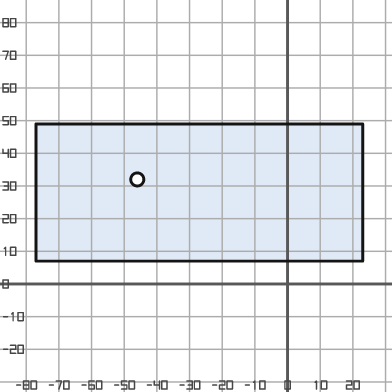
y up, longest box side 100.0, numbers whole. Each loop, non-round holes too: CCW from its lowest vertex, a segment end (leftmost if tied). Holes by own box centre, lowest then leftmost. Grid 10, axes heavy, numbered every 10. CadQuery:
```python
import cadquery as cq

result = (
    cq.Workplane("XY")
    .moveTo(-77.0, 7.0)
    .lineTo(23.0, 7.0)
    .lineTo(23.0, 49.0)
    .lineTo(-77.0, 49.0)
    .close()
    .moveTo(-46.0, 32.0)
    .circle(2.0)
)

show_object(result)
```